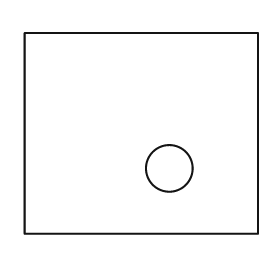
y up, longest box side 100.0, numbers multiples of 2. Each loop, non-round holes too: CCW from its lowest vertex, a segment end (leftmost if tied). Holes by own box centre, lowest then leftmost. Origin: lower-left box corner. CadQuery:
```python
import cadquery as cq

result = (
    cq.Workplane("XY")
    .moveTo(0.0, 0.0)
    .lineTo(100.0, 0.0)
    .lineTo(100.0, 86.0)
    .lineTo(0.0, 86.0)
    .close()
    .moveTo(62.0, 28.0)
    .circle(10.0)
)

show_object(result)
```